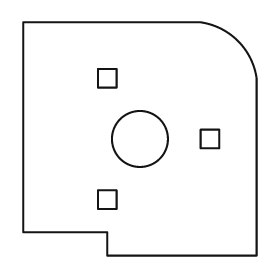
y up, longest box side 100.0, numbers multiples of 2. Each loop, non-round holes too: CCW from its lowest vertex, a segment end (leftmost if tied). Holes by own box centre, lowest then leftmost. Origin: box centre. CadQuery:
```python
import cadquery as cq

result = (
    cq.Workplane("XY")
    .moveTo(-14.0, -50.0)
    .lineTo(50.0, -50.0)
    .lineTo(50.0, 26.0)
    .threePointArc((42.0, 42.0), (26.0, 50.0))
    .lineTo(-50.0, 50.0)
    .lineTo(-50.0, -40.0)
    .lineTo(-14.0, -40.0)
    .close()
    .moveTo(-18.0, -30.0)
    .lineTo(-10.0, -30.0)
    .lineTo(-10.0, -22.0)
    .lineTo(-18.0, -22.0)
    .close()
    .moveTo(0.0, 0.0)
    .circle(12.0)
    .moveTo(26.0, -4.0)
    .lineTo(34.0, -4.0)
    .lineTo(34.0, 4.0)
    .lineTo(26.0, 4.0)
    .close()
    .moveTo(-18.0, 22.0)
    .lineTo(-10.0, 22.0)
    .lineTo(-10.0, 30.0)
    .lineTo(-18.0, 30.0)
    .close()
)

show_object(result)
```